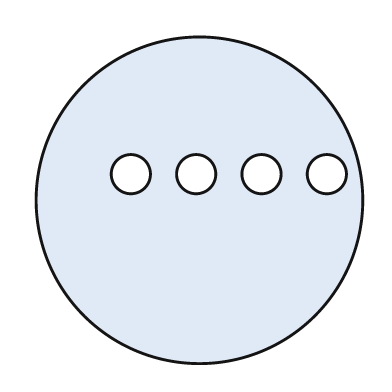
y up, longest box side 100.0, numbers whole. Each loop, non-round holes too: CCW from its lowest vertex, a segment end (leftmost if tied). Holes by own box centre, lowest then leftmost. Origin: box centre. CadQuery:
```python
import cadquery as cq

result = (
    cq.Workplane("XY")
    .moveTo(0.0, 0.0)
    .circle(50.0)
    .moveTo(-21.0, 8.0)
    .circle(6.0)
    .moveTo(-1.0, 8.0)
    .circle(6.0)
    .moveTo(19.0, 8.0)
    .circle(6.0)
    .moveTo(39.0, 8.0)
    .circle(6.0)
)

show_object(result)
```